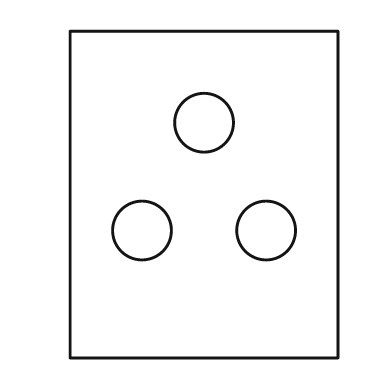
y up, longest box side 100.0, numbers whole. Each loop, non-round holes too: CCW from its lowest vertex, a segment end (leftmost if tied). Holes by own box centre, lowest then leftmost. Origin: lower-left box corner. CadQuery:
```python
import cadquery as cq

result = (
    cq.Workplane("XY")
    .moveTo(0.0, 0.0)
    .lineTo(82.0, 0.0)
    .lineTo(82.0, 100.0)
    .lineTo(0.0, 100.0)
    .close()
    .moveTo(22.0, 39.0)
    .circle(9.0)
    .moveTo(60.0, 39.0)
    .circle(9.0)
    .moveTo(41.0, 72.0)
    .circle(9.0)
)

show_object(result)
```